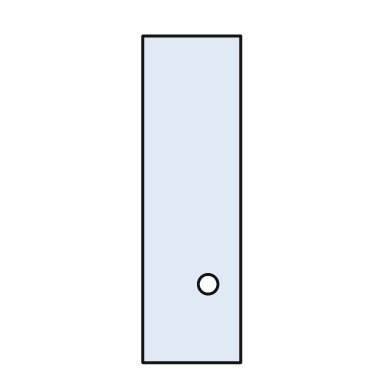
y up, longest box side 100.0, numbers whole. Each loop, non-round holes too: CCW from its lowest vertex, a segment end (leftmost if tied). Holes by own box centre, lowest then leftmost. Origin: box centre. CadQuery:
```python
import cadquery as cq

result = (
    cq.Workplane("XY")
    .moveTo(-15.0, -50.0)
    .lineTo(15.0, -50.0)
    .lineTo(15.0, 50.0)
    .lineTo(-15.0, 50.0)
    .close()
    .moveTo(5.0, -26.0)
    .circle(3.0)
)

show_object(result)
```